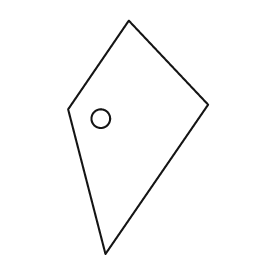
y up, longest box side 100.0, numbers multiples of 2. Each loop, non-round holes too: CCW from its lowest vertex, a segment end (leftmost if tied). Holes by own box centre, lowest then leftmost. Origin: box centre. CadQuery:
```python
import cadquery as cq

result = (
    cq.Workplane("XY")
    .moveTo(-14.0, -50.0)
    .lineTo(30.0, 14.0)
    .lineTo(-4.0, 50.0)
    .lineTo(-30.0, 12.0)
    .close()
    .moveTo(-16.0, 8.0)
    .circle(4.0)
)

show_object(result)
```